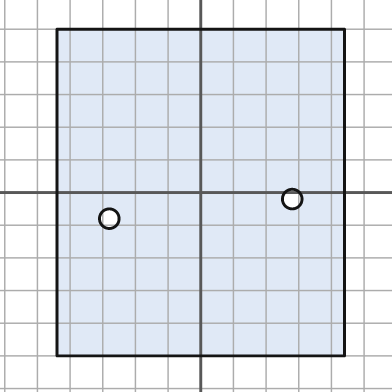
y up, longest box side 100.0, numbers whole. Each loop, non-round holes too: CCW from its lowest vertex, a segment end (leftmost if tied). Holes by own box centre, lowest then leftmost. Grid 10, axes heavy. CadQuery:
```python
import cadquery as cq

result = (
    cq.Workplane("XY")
    .moveTo(-44.0, -50.0)
    .lineTo(44.0, -50.0)
    .lineTo(44.0, 50.0)
    .lineTo(-44.0, 50.0)
    .close()
    .moveTo(-28.0, -8.0)
    .circle(3.0)
    .moveTo(28.0, -2.0)
    .circle(3.0)
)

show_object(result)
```